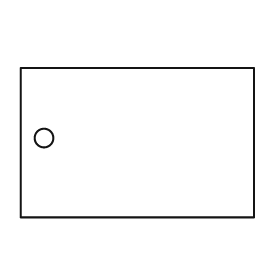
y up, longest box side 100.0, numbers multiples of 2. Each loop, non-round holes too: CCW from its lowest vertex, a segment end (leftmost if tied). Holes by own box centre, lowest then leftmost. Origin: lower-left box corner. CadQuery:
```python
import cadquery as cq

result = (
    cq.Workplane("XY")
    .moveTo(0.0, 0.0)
    .lineTo(100.0, 0.0)
    .lineTo(100.0, 64.0)
    .lineTo(0.0, 64.0)
    .close()
    .moveTo(10.0, 34.0)
    .circle(4.0)
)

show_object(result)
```